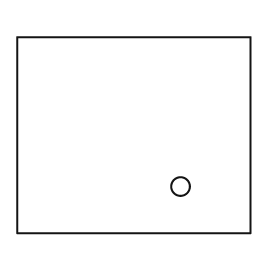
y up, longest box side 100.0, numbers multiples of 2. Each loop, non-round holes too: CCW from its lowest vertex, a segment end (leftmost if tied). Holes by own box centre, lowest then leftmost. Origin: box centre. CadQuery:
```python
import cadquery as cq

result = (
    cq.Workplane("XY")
    .moveTo(-50.0, -42.0)
    .lineTo(50.0, -42.0)
    .lineTo(50.0, 42.0)
    .lineTo(-50.0, 42.0)
    .close()
    .moveTo(20.0, -22.0)
    .circle(4.0)
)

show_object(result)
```